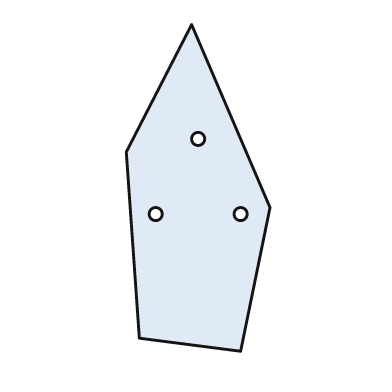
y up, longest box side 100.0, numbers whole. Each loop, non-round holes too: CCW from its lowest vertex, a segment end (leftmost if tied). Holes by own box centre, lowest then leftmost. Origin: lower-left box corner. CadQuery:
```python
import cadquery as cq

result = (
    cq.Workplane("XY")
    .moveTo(35.0, 0.0)
    .lineTo(44.0, 44.0)
    .lineTo(20.0, 100.0)
    .lineTo(0.0, 61.0)
    .lineTo(4.0, 4.0)
    .close()
    .moveTo(9.0, 42.0)
    .circle(2.0)
    .moveTo(35.0, 42.0)
    .circle(2.0)
    .moveTo(22.0, 65.0)
    .circle(2.0)
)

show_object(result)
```